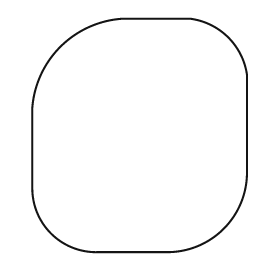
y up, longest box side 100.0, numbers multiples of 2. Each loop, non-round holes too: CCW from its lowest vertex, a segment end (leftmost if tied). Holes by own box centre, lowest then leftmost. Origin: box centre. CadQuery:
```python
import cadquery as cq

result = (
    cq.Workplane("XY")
    .moveTo(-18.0, -50.0)
    .lineTo(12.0, -50.0)
    .threePointArc((36.0, -40.0), (46.0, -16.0))
    .lineTo(46.0, 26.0)
    .threePointArc((38.0, 42.0), (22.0, 50.0))
    .lineTo(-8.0, 50.0)
    .threePointArc((-34.0, 38.0), (-46.0, 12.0))
    .lineTo(-46.0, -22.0)
    .threePointArc((-38.0, -42.0), (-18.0, -50.0))
    .close()
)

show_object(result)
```